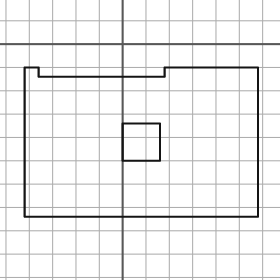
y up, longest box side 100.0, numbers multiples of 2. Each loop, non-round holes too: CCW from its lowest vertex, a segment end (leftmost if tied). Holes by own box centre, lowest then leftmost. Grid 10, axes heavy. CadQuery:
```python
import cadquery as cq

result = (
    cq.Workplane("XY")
    .moveTo(-42.0, -74.0)
    .lineTo(58.0, -74.0)
    .lineTo(58.0, -10.0)
    .lineTo(18.0, -10.0)
    .lineTo(18.0, -14.0)
    .lineTo(-36.0, -14.0)
    .lineTo(-36.0, -10.0)
    .lineTo(-42.0, -10.0)
    .close()
    .moveTo(0.0, -50.0)
    .lineTo(16.0, -50.0)
    .lineTo(16.0, -34.0)
    .lineTo(0.0, -34.0)
    .close()
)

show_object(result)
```